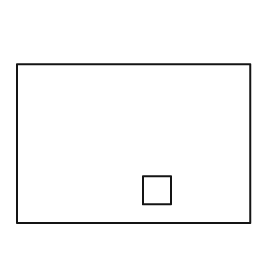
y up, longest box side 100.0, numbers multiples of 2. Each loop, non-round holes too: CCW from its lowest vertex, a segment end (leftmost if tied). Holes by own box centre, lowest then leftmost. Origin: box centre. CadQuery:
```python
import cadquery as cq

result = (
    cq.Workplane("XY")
    .moveTo(-50.0, -34.0)
    .lineTo(50.0, -34.0)
    .lineTo(50.0, 34.0)
    .lineTo(-50.0, 34.0)
    .close()
    .moveTo(4.0, -26.0)
    .lineTo(16.0, -26.0)
    .lineTo(16.0, -14.0)
    .lineTo(4.0, -14.0)
    .close()
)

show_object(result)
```